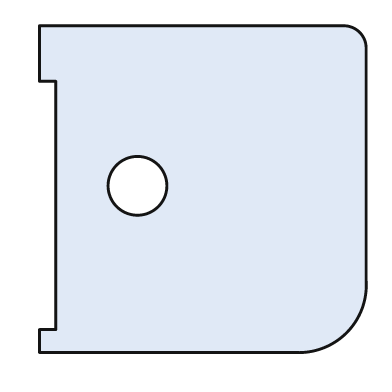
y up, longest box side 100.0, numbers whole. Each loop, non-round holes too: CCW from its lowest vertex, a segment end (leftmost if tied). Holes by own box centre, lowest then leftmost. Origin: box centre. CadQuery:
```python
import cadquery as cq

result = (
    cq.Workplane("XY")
    .moveTo(-50.0, -50.0)
    .lineTo(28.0, -50.0)
    .threePointArc((44.0, -44.0), (50.0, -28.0))
    .lineTo(50.0, 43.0)
    .threePointArc((48.0, 48.0), (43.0, 50.0))
    .lineTo(-50.0, 50.0)
    .lineTo(-50.0, 33.0)
    .lineTo(-45.0, 33.0)
    .lineTo(-45.0, -43.0)
    .lineTo(-50.0, -43.0)
    .close()
    .moveTo(-20.0, 1.0)
    .circle(9.0)
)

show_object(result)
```